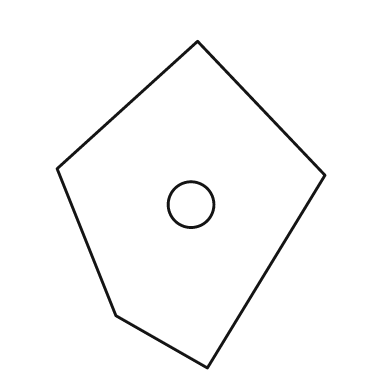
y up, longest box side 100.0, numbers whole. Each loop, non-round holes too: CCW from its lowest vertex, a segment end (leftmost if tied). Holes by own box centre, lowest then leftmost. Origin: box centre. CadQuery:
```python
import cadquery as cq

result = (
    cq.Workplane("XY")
    .moveTo(5.0, -50.0)
    .lineTo(41.0, 9.0)
    .lineTo(2.0, 50.0)
    .lineTo(-41.0, 11.0)
    .lineTo(-23.0, -34.0)
    .close()
    .moveTo(0.0, 0.0)
    .circle(7.0)
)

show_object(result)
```